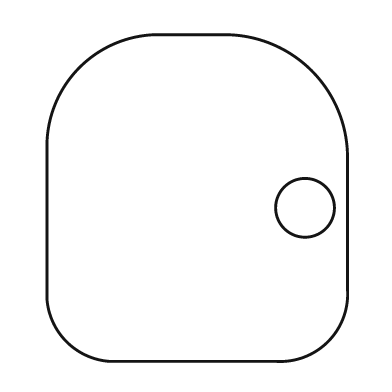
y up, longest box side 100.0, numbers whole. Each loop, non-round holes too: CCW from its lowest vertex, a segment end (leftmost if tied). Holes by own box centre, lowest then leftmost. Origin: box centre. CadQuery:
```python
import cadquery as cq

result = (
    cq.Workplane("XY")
    .moveTo(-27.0, -50.0)
    .lineTo(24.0, -50.0)
    .threePointArc((40.0, -44.0), (46.0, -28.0))
    .lineTo(46.0, 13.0)
    .threePointArc((35.0, 39.0), (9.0, 50.0))
    .lineTo(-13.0, 50.0)
    .threePointArc((-36.0, 40.0), (-46.0, 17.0))
    .lineTo(-46.0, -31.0)
    .threePointArc((-40.0, -44.0), (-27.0, -50.0))
    .close()
    .moveTo(33.0, -3.0)
    .circle(9.0)
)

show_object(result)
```